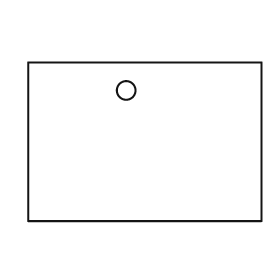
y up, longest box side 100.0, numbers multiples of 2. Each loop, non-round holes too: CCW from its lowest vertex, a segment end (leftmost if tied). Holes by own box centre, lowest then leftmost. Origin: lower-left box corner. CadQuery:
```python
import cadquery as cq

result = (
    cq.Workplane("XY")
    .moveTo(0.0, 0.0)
    .lineTo(100.0, 0.0)
    .lineTo(100.0, 68.0)
    .lineTo(0.0, 68.0)
    .close()
    .moveTo(42.0, 56.0)
    .circle(4.0)
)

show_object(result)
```